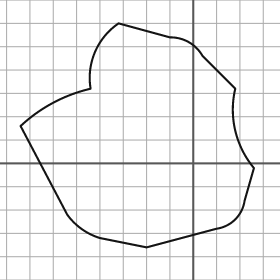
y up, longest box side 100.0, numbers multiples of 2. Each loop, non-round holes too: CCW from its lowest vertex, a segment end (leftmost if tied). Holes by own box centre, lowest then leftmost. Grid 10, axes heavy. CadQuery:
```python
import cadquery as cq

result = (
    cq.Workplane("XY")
    .moveTo(-20.0, -36.0)
    .lineTo(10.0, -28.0)
    .threePointArc((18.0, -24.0), (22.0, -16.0))
    .lineTo(26.0, -2.0)
    .threePointArc((18.0, 14.0), (18.0, 32.0))
    .lineTo(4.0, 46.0)
    .threePointArc((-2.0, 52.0), (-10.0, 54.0))
    .lineTo(-32.0, 60.0)
    .threePointArc((-42.0, 48.0), (-44.0, 32.0))
    .threePointArc((-60.0, 26.0), (-74.0, 16.0))
    .lineTo(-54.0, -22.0)
    .threePointArc((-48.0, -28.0), (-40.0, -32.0))
    .close()
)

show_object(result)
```